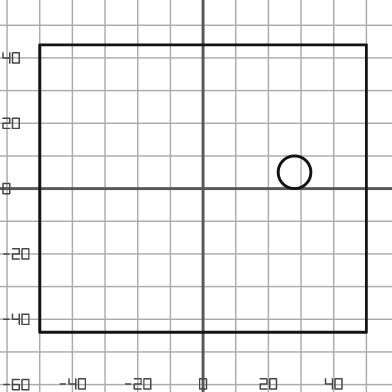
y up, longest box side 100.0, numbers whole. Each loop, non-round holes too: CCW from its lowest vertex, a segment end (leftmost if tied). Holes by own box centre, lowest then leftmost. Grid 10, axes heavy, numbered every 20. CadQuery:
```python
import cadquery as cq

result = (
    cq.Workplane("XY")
    .moveTo(-50.0, -44.0)
    .lineTo(50.0, -44.0)
    .lineTo(50.0, 44.0)
    .lineTo(-50.0, 44.0)
    .close()
    .moveTo(28.0, 5.0)
    .circle(5.0)
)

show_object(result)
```